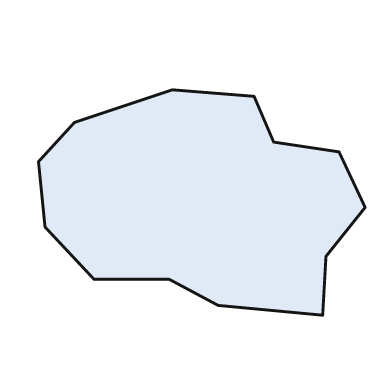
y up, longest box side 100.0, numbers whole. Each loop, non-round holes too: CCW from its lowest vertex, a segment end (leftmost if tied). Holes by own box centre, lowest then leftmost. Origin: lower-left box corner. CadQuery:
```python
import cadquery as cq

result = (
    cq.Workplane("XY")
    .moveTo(87.0, 0.0)
    .lineTo(88.0, 18.0)
    .lineTo(100.0, 33.0)
    .lineTo(92.0, 50.0)
    .lineTo(72.0, 53.0)
    .lineTo(66.0, 67.0)
    .lineTo(41.0, 69.0)
    .lineTo(11.0, 59.0)
    .lineTo(0.0, 47.0)
    .lineTo(2.0, 27.0)
    .lineTo(17.0, 11.0)
    .lineTo(40.0, 11.0)
    .lineTo(55.0, 3.0)
    .close()
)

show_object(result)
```